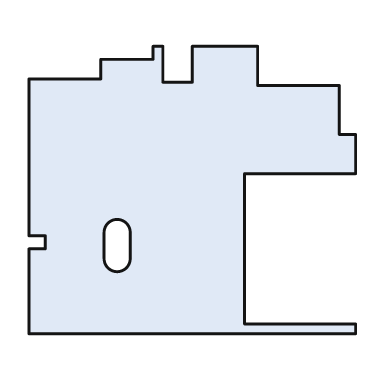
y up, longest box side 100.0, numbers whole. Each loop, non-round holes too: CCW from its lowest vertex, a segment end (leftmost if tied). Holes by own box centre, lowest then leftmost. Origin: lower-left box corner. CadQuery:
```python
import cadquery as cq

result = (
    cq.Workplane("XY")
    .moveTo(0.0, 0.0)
    .lineTo(100.0, 0.0)
    .lineTo(100.0, 3.0)
    .lineTo(66.0, 3.0)
    .lineTo(66.0, 49.0)
    .lineTo(100.0, 49.0)
    .lineTo(100.0, 61.0)
    .lineTo(95.0, 61.0)
    .lineTo(95.0, 76.0)
    .lineTo(70.0, 76.0)
    .lineTo(70.0, 88.0)
    .lineTo(50.0, 88.0)
    .lineTo(50.0, 77.0)
    .lineTo(41.0, 77.0)
    .lineTo(41.0, 88.0)
    .lineTo(38.0, 88.0)
    .lineTo(38.0, 84.0)
    .lineTo(22.0, 84.0)
    .lineTo(22.0, 78.0)
    .lineTo(0.0, 78.0)
    .lineTo(0.0, 30.0)
    .lineTo(5.0, 30.0)
    .lineTo(5.0, 26.0)
    .lineTo(0.0, 26.0)
    .close()
    .moveTo(23.0, 23.0)
    .threePointArc((27.0, 19.0), (31.0, 23.0))
    .lineTo(31.0, 31.0)
    .threePointArc((27.0, 35.0), (23.0, 31.0))
    .close()
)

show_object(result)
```